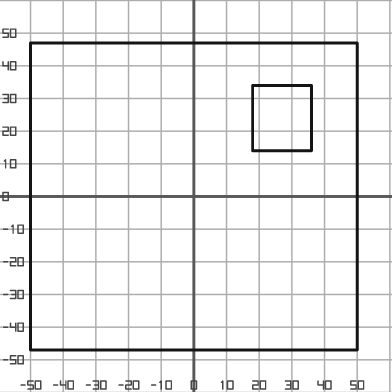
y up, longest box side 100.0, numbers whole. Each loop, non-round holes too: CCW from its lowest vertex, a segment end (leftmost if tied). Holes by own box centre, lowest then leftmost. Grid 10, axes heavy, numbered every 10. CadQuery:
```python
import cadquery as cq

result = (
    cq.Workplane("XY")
    .moveTo(-50.0, -47.0)
    .lineTo(50.0, -47.0)
    .lineTo(50.0, 47.0)
    .lineTo(-50.0, 47.0)
    .close()
    .moveTo(18.0, 14.0)
    .lineTo(36.0, 14.0)
    .lineTo(36.0, 34.0)
    .lineTo(18.0, 34.0)
    .close()
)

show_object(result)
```